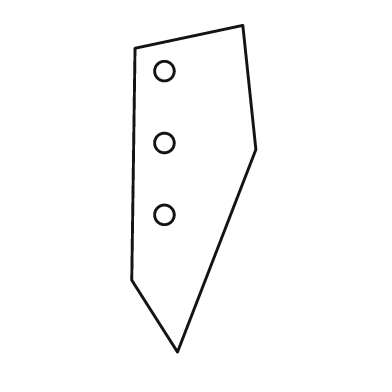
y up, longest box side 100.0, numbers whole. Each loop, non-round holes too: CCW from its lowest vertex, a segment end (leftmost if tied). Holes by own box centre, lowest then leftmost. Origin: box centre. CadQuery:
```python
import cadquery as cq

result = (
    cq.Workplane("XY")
    .moveTo(-5.0, -50.0)
    .lineTo(19.0, 12.0)
    .lineTo(15.0, 50.0)
    .lineTo(-18.0, 43.0)
    .lineTo(-19.0, -28.0)
    .close()
    .moveTo(-9.0, -8.0)
    .circle(3.0)
    .moveTo(-9.0, 14.0)
    .circle(3.0)
    .moveTo(-9.0, 36.0)
    .circle(3.0)
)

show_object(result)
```